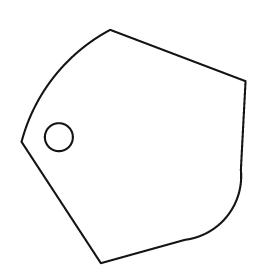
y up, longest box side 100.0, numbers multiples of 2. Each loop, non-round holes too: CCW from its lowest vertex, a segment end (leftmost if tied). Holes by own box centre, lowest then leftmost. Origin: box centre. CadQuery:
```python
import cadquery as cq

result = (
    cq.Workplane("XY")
    .moveTo(-14.0, -50.0)
    .lineTo(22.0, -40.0)
    .threePointArc((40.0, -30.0), (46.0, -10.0))
    .lineTo(48.0, 28.0)
    .lineTo(-10.0, 50.0)
    .threePointArc((-34.0, 30.0), (-48.0, 2.0))
    .close()
    .moveTo(-32.0, 4.0)
    .circle(6.0)
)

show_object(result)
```